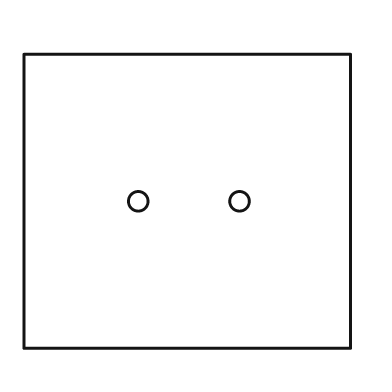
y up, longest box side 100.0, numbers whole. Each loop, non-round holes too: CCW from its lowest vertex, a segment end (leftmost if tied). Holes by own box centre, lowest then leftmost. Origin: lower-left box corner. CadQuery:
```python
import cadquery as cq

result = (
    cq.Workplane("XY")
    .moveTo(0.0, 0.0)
    .lineTo(100.0, 0.0)
    .lineTo(100.0, 90.0)
    .lineTo(0.0, 90.0)
    .close()
    .moveTo(35.0, 45.0)
    .circle(3.0)
    .moveTo(66.0, 45.0)
    .circle(3.0)
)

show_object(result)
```